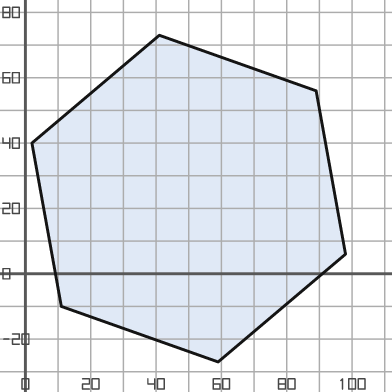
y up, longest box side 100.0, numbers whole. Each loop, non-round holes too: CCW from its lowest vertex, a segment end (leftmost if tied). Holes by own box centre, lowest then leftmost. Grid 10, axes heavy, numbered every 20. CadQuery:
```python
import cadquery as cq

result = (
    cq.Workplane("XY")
    .moveTo(59.0, -27.0)
    .lineTo(98.0, 6.0)
    .lineTo(89.0, 56.0)
    .lineTo(41.0, 73.0)
    .lineTo(2.0, 40.0)
    .lineTo(11.0, -10.0)
    .close()
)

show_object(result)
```